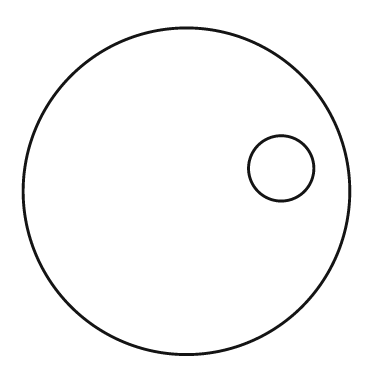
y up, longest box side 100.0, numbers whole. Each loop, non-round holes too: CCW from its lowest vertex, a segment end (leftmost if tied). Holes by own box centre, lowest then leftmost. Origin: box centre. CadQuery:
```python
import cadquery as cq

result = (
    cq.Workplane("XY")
    .moveTo(0.0, 0.0)
    .circle(50.0)
    .moveTo(29.0, 7.0)
    .circle(10.0)
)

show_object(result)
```